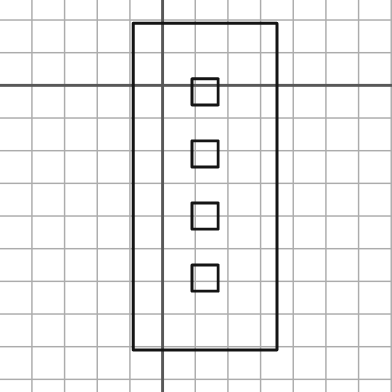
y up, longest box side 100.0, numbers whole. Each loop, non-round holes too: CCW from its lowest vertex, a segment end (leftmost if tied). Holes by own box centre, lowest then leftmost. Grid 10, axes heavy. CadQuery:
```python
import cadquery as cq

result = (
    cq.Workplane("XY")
    .moveTo(-9.0, -81.0)
    .lineTo(35.0, -81.0)
    .lineTo(35.0, 19.0)
    .lineTo(-9.0, 19.0)
    .close()
    .moveTo(9.0, -63.0)
    .lineTo(17.0, -63.0)
    .lineTo(17.0, -55.0)
    .lineTo(9.0, -55.0)
    .close()
    .moveTo(9.0, -44.0)
    .lineTo(17.0, -44.0)
    .lineTo(17.0, -36.0)
    .lineTo(9.0, -36.0)
    .close()
    .moveTo(9.0, -25.0)
    .lineTo(17.0, -25.0)
    .lineTo(17.0, -17.0)
    .lineTo(9.0, -17.0)
    .close()
    .moveTo(9.0, -6.0)
    .lineTo(17.0, -6.0)
    .lineTo(17.0, 2.0)
    .lineTo(9.0, 2.0)
    .close()
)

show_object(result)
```